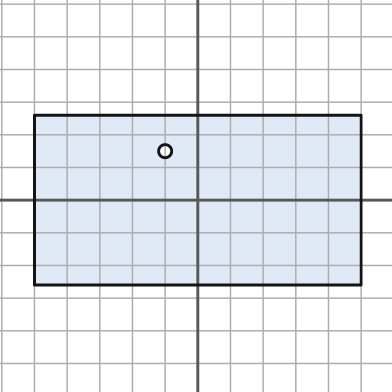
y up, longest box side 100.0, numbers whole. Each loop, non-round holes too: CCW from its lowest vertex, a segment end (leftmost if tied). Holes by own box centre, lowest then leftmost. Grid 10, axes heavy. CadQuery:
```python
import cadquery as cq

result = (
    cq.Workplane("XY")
    .moveTo(-50.0, -26.0)
    .lineTo(50.0, -26.0)
    .lineTo(50.0, 26.0)
    .lineTo(-50.0, 26.0)
    .close()
    .moveTo(-10.0, 15.0)
    .circle(2.0)
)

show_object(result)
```